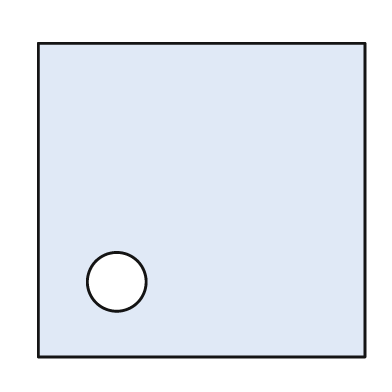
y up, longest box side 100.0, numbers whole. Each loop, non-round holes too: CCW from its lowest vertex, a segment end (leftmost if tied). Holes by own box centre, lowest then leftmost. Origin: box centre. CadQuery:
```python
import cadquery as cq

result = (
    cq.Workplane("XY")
    .moveTo(-50.0, -48.0)
    .lineTo(50.0, -48.0)
    .lineTo(50.0, 48.0)
    .lineTo(-50.0, 48.0)
    .close()
    .moveTo(-26.0, -25.0)
    .circle(9.0)
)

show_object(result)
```